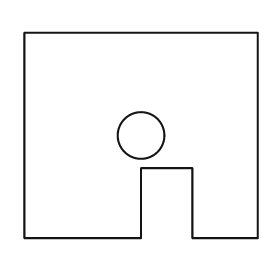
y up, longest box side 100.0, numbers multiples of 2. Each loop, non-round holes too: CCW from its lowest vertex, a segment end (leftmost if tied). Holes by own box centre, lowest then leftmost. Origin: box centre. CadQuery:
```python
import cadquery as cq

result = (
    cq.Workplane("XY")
    .moveTo(-50.0, -44.0)
    .lineTo(0.0, -44.0)
    .lineTo(0.0, -14.0)
    .lineTo(22.0, -14.0)
    .lineTo(22.0, -44.0)
    .lineTo(50.0, -44.0)
    .lineTo(50.0, 44.0)
    .lineTo(-50.0, 44.0)
    .close()
    .moveTo(0.0, 0.0)
    .circle(10.0)
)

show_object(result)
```